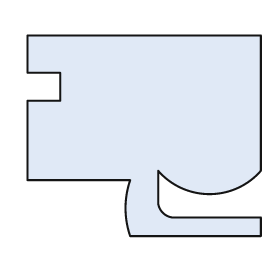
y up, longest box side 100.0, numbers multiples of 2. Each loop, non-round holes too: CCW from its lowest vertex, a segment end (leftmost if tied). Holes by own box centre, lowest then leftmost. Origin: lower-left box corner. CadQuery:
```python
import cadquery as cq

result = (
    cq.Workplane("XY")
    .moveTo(44.0, 0.0)
    .lineTo(100.0, 0.0)
    .lineTo(100.0, 8.0)
    .lineTo(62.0, 8.0)
    .threePointArc((58.0, 10.0), (56.0, 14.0))
    .lineTo(56.0, 28.0)
    .threePointArc((78.0, 18.0), (100.0, 28.0))
    .lineTo(100.0, 86.0)
    .lineTo(0.0, 86.0)
    .lineTo(0.0, 70.0)
    .lineTo(14.0, 70.0)
    .lineTo(14.0, 58.0)
    .lineTo(0.0, 58.0)
    .lineTo(0.0, 24.0)
    .lineTo(44.0, 24.0)
    .threePointArc((42.0, 12.0), (44.0, 0.0))
    .close()
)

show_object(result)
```